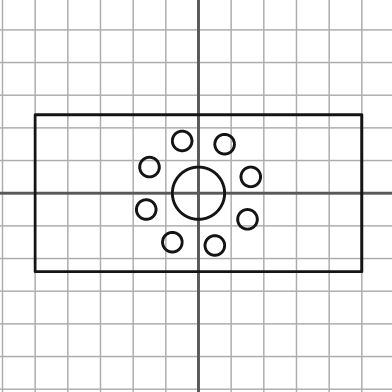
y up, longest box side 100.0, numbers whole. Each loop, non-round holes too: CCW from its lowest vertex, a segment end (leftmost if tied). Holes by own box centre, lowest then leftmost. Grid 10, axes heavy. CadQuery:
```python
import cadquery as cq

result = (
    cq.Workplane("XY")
    .moveTo(-50.0, -24.0)
    .lineTo(50.0, -24.0)
    .lineTo(50.0, 24.0)
    .lineTo(-50.0, 24.0)
    .close()
    .moveTo(5.0, -16.0)
    .circle(3.0)
    .moveTo(-8.0, -15.0)
    .circle(3.0)
    .moveTo(15.0, -8.0)
    .circle(3.0)
    .moveTo(-16.0, -5.0)
    .circle(3.0)
    .moveTo(0.0, 0.0)
    .circle(8.0)
    .moveTo(16.0, 5.0)
    .circle(3.0)
    .moveTo(-15.0, 8.0)
    .circle(3.0)
    .moveTo(8.0, 15.0)
    .circle(3.0)
    .moveTo(-5.0, 16.0)
    .circle(3.0)
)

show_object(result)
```